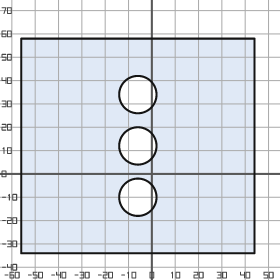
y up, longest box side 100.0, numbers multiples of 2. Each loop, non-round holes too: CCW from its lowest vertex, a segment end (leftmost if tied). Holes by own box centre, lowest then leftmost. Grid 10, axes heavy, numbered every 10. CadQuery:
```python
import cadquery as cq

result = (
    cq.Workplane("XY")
    .moveTo(-56.0, -34.0)
    .lineTo(44.0, -34.0)
    .lineTo(44.0, 58.0)
    .lineTo(-56.0, 58.0)
    .close()
    .moveTo(-6.0, -10.0)
    .circle(8.0)
    .moveTo(-6.0, 12.0)
    .circle(8.0)
    .moveTo(-6.0, 34.0)
    .circle(8.0)
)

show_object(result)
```